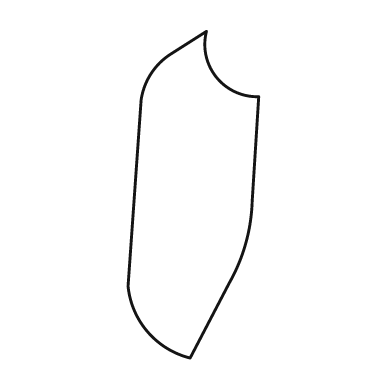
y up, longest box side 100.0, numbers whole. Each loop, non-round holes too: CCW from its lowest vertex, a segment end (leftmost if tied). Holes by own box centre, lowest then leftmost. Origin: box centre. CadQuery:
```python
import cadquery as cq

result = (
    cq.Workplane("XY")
    .moveTo(-1.0, -50.0)
    .lineTo(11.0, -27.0)
    .threePointArc((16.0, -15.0), (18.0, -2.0))
    .lineTo(20.0, 30.0)
    .threePointArc((7.0, 36.0), (4.0, 50.0))
    .lineTo(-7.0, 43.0)
    .threePointArc((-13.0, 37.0), (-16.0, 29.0))
    .lineTo(-20.0, -28.0)
    .threePointArc((-14.0, -42.0), (-1.0, -50.0))
    .close()
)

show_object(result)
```